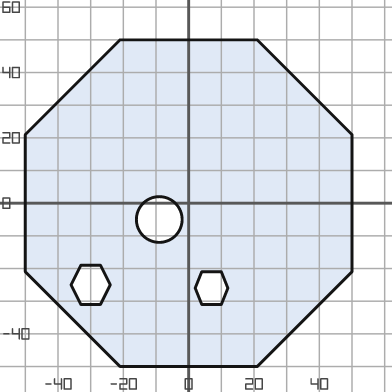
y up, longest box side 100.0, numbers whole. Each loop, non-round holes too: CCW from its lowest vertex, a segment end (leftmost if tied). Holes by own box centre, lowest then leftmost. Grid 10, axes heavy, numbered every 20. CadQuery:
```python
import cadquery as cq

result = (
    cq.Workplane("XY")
    .moveTo(-21.0, -50.0)
    .lineTo(21.0, -50.0)
    .lineTo(50.0, -21.0)
    .lineTo(50.0, 21.0)
    .lineTo(21.0, 50.0)
    .lineTo(-21.0, 50.0)
    .lineTo(-50.0, 21.0)
    .lineTo(-50.0, -21.0)
    .close()
    .moveTo(4.0, -31.0)
    .lineTo(10.0, -31.0)
    .lineTo(12.0, -26.0)
    .lineTo(10.0, -21.0)
    .lineTo(4.0, -21.0)
    .lineTo(2.0, -26.0)
    .close()
    .moveTo(-33.0, -31.0)
    .lineTo(-27.0, -31.0)
    .lineTo(-24.0, -25.0)
    .lineTo(-27.0, -19.0)
    .lineTo(-33.0, -19.0)
    .lineTo(-36.0, -25.0)
    .close()
    .moveTo(-9.0, -5.0)
    .circle(7.0)
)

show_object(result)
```